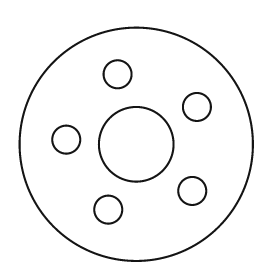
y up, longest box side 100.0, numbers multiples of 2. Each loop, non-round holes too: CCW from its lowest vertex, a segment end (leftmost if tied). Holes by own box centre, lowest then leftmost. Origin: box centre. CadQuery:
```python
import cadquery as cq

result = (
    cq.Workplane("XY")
    .moveTo(0.0, 0.0)
    .circle(50.0)
    .moveTo(-12.0, -28.0)
    .circle(6.0)
    .moveTo(24.0, -20.0)
    .circle(6.0)
    .moveTo(0.0, 0.0)
    .circle(16.0)
    .moveTo(-30.0, 2.0)
    .circle(6.0)
    .moveTo(26.0, 16.0)
    .circle(6.0)
    .moveTo(-8.0, 30.0)
    .circle(6.0)
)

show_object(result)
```